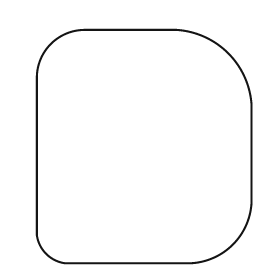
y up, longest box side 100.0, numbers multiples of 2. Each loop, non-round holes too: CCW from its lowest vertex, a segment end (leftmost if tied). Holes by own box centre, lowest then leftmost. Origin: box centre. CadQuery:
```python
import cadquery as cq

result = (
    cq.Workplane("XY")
    .moveTo(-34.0, -50.0)
    .lineTo(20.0, -50.0)
    .threePointArc((38.0, -42.0), (46.0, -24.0))
    .lineTo(46.0, 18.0)
    .threePointArc((36.0, 40.0), (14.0, 50.0))
    .lineTo(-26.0, 50.0)
    .threePointArc((-40.0, 44.0), (-46.0, 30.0))
    .lineTo(-46.0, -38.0)
    .threePointArc((-42.0, -46.0), (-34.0, -50.0))
    .close()
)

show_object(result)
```